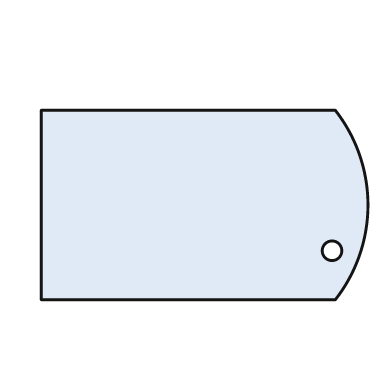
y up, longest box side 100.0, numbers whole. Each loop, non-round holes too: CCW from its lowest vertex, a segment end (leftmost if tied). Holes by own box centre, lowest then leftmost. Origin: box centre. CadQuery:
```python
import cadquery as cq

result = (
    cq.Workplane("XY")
    .moveTo(-50.0, -29.0)
    .lineTo(40.0, -29.0)
    .threePointArc((50.0, 0.0), (40.0, 29.0))
    .lineTo(-50.0, 29.0)
    .close()
    .moveTo(39.0, -14.0)
    .circle(3.0)
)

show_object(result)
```